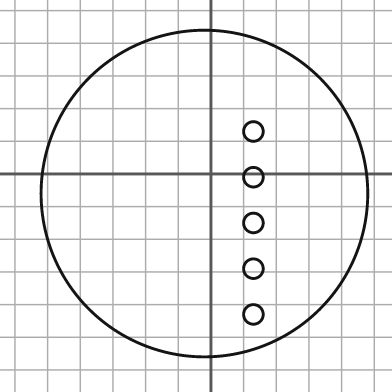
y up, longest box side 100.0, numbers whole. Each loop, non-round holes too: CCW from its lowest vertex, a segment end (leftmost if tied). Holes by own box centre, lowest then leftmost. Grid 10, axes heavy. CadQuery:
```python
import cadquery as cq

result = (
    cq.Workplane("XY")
    .moveTo(-2.0, -6.0)
    .circle(50.0)
    .moveTo(13.0, -43.0)
    .circle(3.0)
    .moveTo(13.0, -29.0)
    .circle(3.0)
    .moveTo(13.0, -15.0)
    .circle(3.0)
    .moveTo(13.0, -1.0)
    .circle(3.0)
    .moveTo(13.0, 13.0)
    .circle(3.0)
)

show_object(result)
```